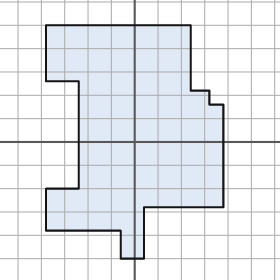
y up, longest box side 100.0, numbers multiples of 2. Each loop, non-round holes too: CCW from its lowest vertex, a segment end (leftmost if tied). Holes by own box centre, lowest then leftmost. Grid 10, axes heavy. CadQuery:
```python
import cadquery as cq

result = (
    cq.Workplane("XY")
    .moveTo(-6.0, -50.0)
    .lineTo(4.0, -50.0)
    .lineTo(4.0, -28.0)
    .lineTo(38.0, -28.0)
    .lineTo(38.0, 16.0)
    .lineTo(32.0, 16.0)
    .lineTo(32.0, 22.0)
    .lineTo(24.0, 22.0)
    .lineTo(24.0, 50.0)
    .lineTo(-38.0, 50.0)
    .lineTo(-38.0, 26.0)
    .lineTo(-24.0, 26.0)
    .lineTo(-24.0, -20.0)
    .lineTo(-38.0, -20.0)
    .lineTo(-38.0, -38.0)
    .lineTo(-6.0, -38.0)
    .close()
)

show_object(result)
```